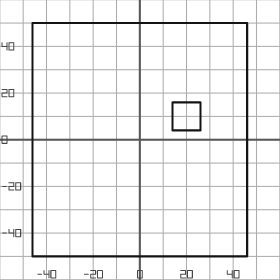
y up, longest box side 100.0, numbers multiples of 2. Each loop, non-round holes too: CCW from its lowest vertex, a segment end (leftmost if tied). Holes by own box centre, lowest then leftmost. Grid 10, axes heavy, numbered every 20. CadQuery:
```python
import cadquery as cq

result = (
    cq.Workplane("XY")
    .moveTo(-46.0, -50.0)
    .lineTo(46.0, -50.0)
    .lineTo(46.0, 50.0)
    .lineTo(-46.0, 50.0)
    .close()
    .moveTo(14.0, 4.0)
    .lineTo(26.0, 4.0)
    .lineTo(26.0, 16.0)
    .lineTo(14.0, 16.0)
    .close()
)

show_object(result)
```